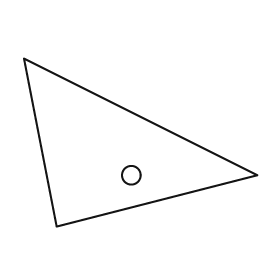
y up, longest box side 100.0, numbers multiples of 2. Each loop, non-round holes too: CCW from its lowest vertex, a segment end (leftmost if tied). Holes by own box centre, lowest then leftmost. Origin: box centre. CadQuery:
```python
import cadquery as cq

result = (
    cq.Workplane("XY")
    .moveTo(-36.0, -36.0)
    .lineTo(50.0, -14.0)
    .lineTo(-50.0, 36.0)
    .close()
    .moveTo(-4.0, -14.0)
    .circle(4.0)
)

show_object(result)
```